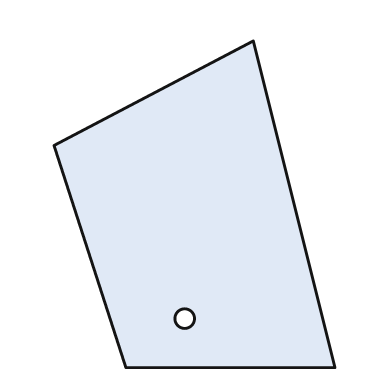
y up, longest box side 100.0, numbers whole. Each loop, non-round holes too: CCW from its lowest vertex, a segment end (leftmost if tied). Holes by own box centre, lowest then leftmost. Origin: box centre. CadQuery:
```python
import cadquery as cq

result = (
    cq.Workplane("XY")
    .moveTo(-21.0, -50.0)
    .lineTo(43.0, -50.0)
    .lineTo(18.0, 50.0)
    .lineTo(-43.0, 18.0)
    .close()
    .moveTo(-3.0, -35.0)
    .circle(3.0)
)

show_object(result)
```